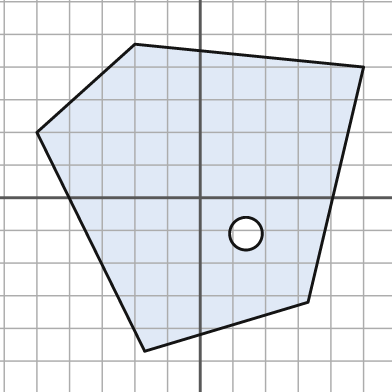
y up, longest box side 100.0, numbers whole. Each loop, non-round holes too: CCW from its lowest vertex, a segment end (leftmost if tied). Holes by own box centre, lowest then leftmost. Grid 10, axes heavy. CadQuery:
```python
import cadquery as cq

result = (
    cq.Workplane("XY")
    .moveTo(-17.0, -47.0)
    .lineTo(33.0, -32.0)
    .lineTo(50.0, 40.0)
    .lineTo(-20.0, 47.0)
    .lineTo(-50.0, 20.0)
    .close()
    .moveTo(14.0, -11.0)
    .circle(5.0)
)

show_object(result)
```